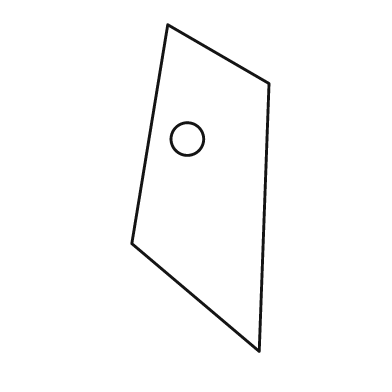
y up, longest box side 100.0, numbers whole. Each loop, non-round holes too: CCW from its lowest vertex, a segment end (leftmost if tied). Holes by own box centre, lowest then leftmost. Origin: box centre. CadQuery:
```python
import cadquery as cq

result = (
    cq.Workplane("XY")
    .moveTo(18.0, -50.0)
    .lineTo(21.0, 32.0)
    .lineTo(-10.0, 50.0)
    .lineTo(-21.0, -17.0)
    .close()
    .moveTo(-4.0, 15.0)
    .circle(5.0)
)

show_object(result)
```